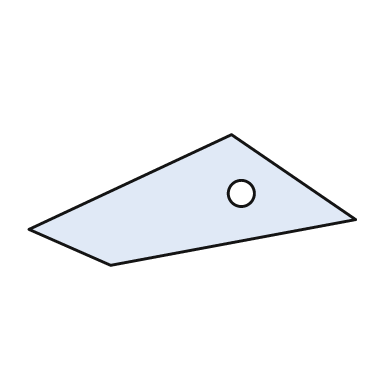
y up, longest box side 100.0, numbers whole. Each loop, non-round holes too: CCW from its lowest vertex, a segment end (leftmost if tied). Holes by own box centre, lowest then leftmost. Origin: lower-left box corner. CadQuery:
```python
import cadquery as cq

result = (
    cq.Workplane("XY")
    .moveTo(25.0, 0.0)
    .lineTo(100.0, 14.0)
    .lineTo(62.0, 40.0)
    .lineTo(0.0, 11.0)
    .close()
    .moveTo(65.0, 22.0)
    .circle(4.0)
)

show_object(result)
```